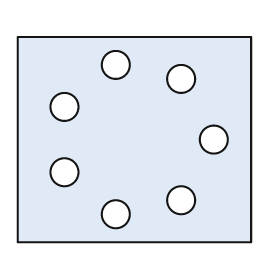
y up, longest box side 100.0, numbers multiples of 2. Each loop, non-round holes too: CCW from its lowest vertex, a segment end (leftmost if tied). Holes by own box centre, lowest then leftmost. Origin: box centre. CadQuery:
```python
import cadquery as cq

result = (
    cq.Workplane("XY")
    .moveTo(-50.0, -44.0)
    .lineTo(50.0, -44.0)
    .lineTo(50.0, 44.0)
    .lineTo(-50.0, 44.0)
    .close()
    .moveTo(-8.0, -32.0)
    .circle(6.0)
    .moveTo(20.0, -26.0)
    .circle(6.0)
    .moveTo(-30.0, -14.0)
    .circle(6.0)
    .moveTo(34.0, 0.0)
    .circle(6.0)
    .moveTo(-30.0, 14.0)
    .circle(6.0)
    .moveTo(20.0, 26.0)
    .circle(6.0)
    .moveTo(-8.0, 32.0)
    .circle(6.0)
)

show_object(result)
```